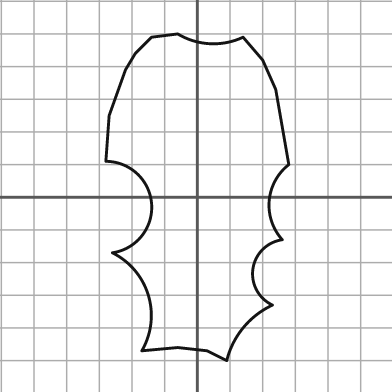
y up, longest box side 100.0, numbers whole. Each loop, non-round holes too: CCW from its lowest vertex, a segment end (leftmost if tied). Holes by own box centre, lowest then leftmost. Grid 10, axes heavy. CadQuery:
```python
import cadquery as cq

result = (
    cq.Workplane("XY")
    .moveTo(9.0, -50.0)
    .threePointArc((14.0, -40.0), (23.0, -33.0))
    .threePointArc((17.0, -22.0), (26.0, -13.0))
    .threePointArc((22.0, -1.0), (28.0, 10.0))
    .lineTo(24.0, 33.0)
    .lineTo(20.0, 42.0)
    .lineTo(14.0, 49.0)
    .threePointArc((4.0, 47.0), (-6.0, 50.0))
    .lineTo(-14.0, 49.0)
    .lineTo(-19.0, 44.0)
    .lineTo(-22.0, 39.0)
    .lineTo(-27.0, 25.0)
    .lineTo(-28.0, 11.0)
    .threePointArc((-14.0, -2.0), (-26.0, -17.0))
    .threePointArc((-15.0, -30.0), (-17.0, -47.0))
    .lineTo(-6.0, -46.0)
    .lineTo(3.0, -47.0)
    .close()
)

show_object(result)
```